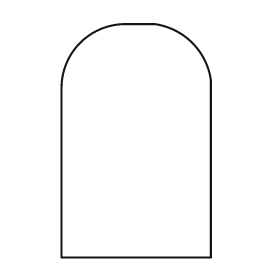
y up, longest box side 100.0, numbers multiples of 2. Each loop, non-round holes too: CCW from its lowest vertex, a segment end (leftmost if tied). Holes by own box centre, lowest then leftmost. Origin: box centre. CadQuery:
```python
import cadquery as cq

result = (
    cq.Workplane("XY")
    .moveTo(-32.0, -50.0)
    .lineTo(32.0, -50.0)
    .lineTo(32.0, 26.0)
    .threePointArc((24.0, 42.0), (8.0, 50.0))
    .lineTo(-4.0, 50.0)
    .threePointArc((-24.0, 42.0), (-32.0, 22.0))
    .close()
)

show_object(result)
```